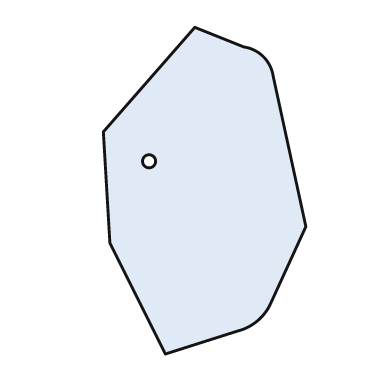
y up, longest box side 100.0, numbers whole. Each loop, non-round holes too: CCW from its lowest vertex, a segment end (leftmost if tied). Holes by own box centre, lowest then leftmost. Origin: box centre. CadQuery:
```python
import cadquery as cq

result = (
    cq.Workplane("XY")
    .moveTo(-12.0, -50.0)
    .lineTo(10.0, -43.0)
    .threePointArc((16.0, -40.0), (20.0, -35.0))
    .lineTo(31.0, -11.0)
    .lineTo(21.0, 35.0)
    .threePointArc((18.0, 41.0), (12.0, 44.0))
    .lineTo(-3.0, 50.0)
    .lineTo(-31.0, 18.0)
    .lineTo(-29.0, -16.0)
    .close()
    .moveTo(-17.0, 9.0)
    .circle(2.0)
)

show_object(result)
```